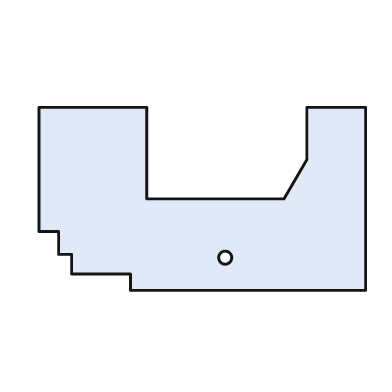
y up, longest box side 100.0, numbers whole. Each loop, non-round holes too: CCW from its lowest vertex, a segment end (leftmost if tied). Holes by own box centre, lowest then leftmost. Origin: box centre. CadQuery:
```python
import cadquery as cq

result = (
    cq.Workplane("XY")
    .moveTo(-22.0, -28.0)
    .lineTo(50.0, -28.0)
    .lineTo(50.0, 28.0)
    .lineTo(32.0, 28.0)
    .lineTo(32.0, 12.0)
    .lineTo(25.0, 0.0)
    .lineTo(-17.0, 0.0)
    .lineTo(-17.0, 28.0)
    .lineTo(-50.0, 28.0)
    .lineTo(-50.0, -10.0)
    .lineTo(-44.0, -10.0)
    .lineTo(-44.0, -17.0)
    .lineTo(-40.0, -17.0)
    .lineTo(-40.0, -23.0)
    .lineTo(-22.0, -23.0)
    .close()
    .moveTo(7.0, -18.0)
    .circle(2.0)
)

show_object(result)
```